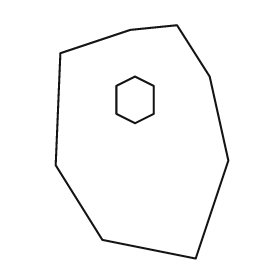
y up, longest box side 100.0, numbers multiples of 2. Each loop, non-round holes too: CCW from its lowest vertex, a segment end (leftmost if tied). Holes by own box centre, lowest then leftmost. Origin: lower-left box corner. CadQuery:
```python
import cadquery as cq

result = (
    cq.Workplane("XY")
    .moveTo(60.0, 0.0)
    .lineTo(74.0, 42.0)
    .lineTo(66.0, 78.0)
    .lineTo(52.0, 100.0)
    .lineTo(32.0, 98.0)
    .lineTo(2.0, 88.0)
    .lineTo(0.0, 40.0)
    .lineTo(20.0, 8.0)
    .close()
    .moveTo(34.0, 58.0)
    .lineTo(42.0, 62.0)
    .lineTo(42.0, 74.0)
    .lineTo(34.0, 78.0)
    .lineTo(26.0, 74.0)
    .lineTo(26.0, 62.0)
    .close()
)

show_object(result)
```